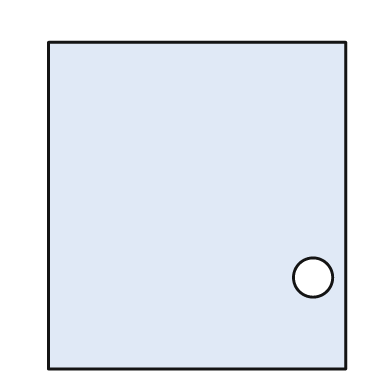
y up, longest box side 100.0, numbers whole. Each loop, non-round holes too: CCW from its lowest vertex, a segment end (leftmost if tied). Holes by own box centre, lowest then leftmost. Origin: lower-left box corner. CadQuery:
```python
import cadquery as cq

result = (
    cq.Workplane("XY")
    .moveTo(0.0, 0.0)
    .lineTo(91.0, 0.0)
    .lineTo(91.0, 100.0)
    .lineTo(0.0, 100.0)
    .close()
    .moveTo(81.0, 28.0)
    .circle(6.0)
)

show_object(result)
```